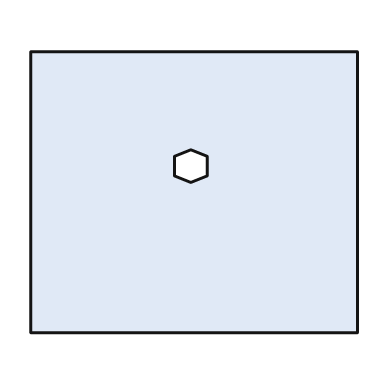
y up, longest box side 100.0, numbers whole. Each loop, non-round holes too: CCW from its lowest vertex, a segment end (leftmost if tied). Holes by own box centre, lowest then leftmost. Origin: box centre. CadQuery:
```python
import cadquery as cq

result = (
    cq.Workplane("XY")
    .moveTo(-50.0, -43.0)
    .lineTo(50.0, -43.0)
    .lineTo(50.0, 43.0)
    .lineTo(-50.0, 43.0)
    .close()
    .moveTo(-1.0, 3.0)
    .lineTo(4.0, 5.0)
    .lineTo(4.0, 11.0)
    .lineTo(-1.0, 13.0)
    .lineTo(-6.0, 11.0)
    .lineTo(-6.0, 5.0)
    .close()
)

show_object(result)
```